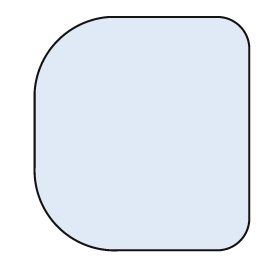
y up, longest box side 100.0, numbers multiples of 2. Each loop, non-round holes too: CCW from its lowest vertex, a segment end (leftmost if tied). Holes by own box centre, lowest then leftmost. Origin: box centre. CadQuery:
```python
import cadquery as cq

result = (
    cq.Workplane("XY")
    .moveTo(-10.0, -50.0)
    .lineTo(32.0, -50.0)
    .threePointArc((42.0, -46.0), (46.0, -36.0))
    .lineTo(46.0, 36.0)
    .threePointArc((42.0, 46.0), (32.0, 50.0))
    .lineTo(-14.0, 50.0)
    .threePointArc((-36.0, 40.0), (-46.0, 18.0))
    .lineTo(-46.0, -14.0)
    .threePointArc((-36.0, -40.0), (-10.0, -50.0))
    .close()
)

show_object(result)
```